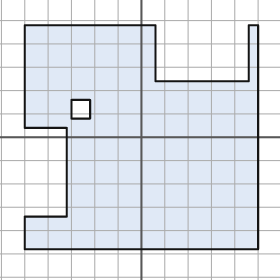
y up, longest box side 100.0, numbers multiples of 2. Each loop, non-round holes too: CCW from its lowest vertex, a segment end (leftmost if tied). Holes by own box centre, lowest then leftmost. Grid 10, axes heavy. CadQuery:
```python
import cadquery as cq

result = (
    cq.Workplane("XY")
    .moveTo(-50.0, -48.0)
    .lineTo(50.0, -48.0)
    .lineTo(50.0, 48.0)
    .lineTo(46.0, 48.0)
    .lineTo(46.0, 24.0)
    .lineTo(6.0, 24.0)
    .lineTo(6.0, 48.0)
    .lineTo(-50.0, 48.0)
    .lineTo(-50.0, 4.0)
    .lineTo(-32.0, 4.0)
    .lineTo(-32.0, -34.0)
    .lineTo(-50.0, -34.0)
    .close()
    .moveTo(-30.0, 8.0)
    .lineTo(-22.0, 8.0)
    .lineTo(-22.0, 16.0)
    .lineTo(-30.0, 16.0)
    .close()
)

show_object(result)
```